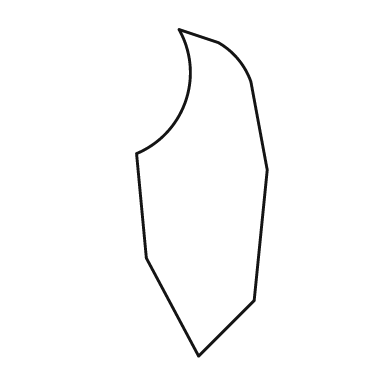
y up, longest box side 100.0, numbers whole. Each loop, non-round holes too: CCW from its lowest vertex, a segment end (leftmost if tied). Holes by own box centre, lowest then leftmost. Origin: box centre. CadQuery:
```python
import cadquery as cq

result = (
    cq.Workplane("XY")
    .moveTo(-1.0, -50.0)
    .lineTo(16.0, -33.0)
    .lineTo(20.0, 7.0)
    .lineTo(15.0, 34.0)
    .threePointArc((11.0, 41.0), (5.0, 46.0))
    .lineTo(-7.0, 50.0)
    .threePointArc((-5.0, 28.0), (-20.0, 12.0))
    .lineTo(-17.0, -20.0)
    .close()
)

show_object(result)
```